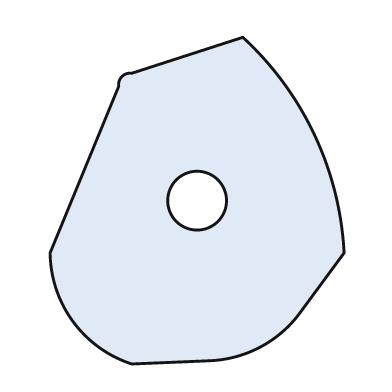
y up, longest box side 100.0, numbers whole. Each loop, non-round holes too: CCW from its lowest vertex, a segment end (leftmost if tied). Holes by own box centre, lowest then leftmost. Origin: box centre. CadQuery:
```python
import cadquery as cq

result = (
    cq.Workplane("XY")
    .moveTo(-20.0, -50.0)
    .lineTo(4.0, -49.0)
    .threePointArc((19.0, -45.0), (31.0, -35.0))
    .lineTo(45.0, -16.0)
    .threePointArc((36.0, 20.0), (14.0, 50.0))
    .lineTo(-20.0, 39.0)
    .threePointArc((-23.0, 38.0), (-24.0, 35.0))
    .lineTo(-45.0, -16.0)
    .threePointArc((-38.0, -37.0), (-20.0, -50.0))
    .close()
    .moveTo(0.0, 0.0)
    .circle(9.0)
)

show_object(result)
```